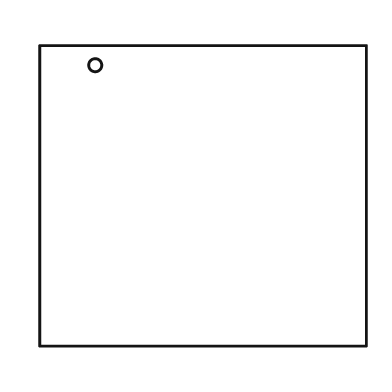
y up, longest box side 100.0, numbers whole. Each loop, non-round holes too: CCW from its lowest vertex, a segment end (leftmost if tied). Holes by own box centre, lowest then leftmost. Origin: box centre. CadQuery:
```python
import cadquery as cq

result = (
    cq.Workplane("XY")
    .moveTo(-50.0, -46.0)
    .lineTo(50.0, -46.0)
    .lineTo(50.0, 46.0)
    .lineTo(-50.0, 46.0)
    .close()
    .moveTo(-33.0, 40.0)
    .circle(2.0)
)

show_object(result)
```